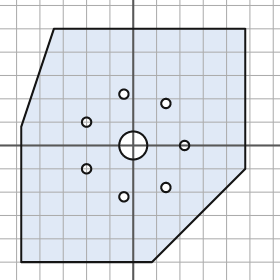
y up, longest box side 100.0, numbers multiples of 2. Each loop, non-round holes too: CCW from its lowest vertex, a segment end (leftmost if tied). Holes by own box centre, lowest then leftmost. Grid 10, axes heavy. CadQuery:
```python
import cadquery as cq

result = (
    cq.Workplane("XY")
    .moveTo(-48.0, -50.0)
    .lineTo(8.0, -50.0)
    .lineTo(48.0, -10.0)
    .lineTo(48.0, 50.0)
    .lineTo(-34.0, 50.0)
    .lineTo(-48.0, 8.0)
    .close()
    .moveTo(-4.0, -22.0)
    .circle(2.0)
    .moveTo(14.0, -18.0)
    .circle(2.0)
    .moveTo(-20.0, -10.0)
    .circle(2.0)
    .moveTo(0.0, 0.0)
    .circle(6.0)
    .moveTo(22.0, 0.0)
    .circle(2.0)
    .moveTo(-20.0, 10.0)
    .circle(2.0)
    .moveTo(14.0, 18.0)
    .circle(2.0)
    .moveTo(-4.0, 22.0)
    .circle(2.0)
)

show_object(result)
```